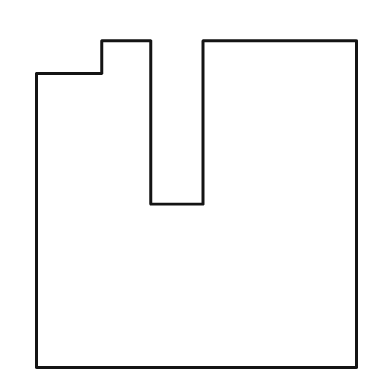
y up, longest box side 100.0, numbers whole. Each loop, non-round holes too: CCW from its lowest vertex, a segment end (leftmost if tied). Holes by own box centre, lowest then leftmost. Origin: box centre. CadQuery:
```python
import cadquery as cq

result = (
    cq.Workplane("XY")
    .moveTo(-49.0, -50.0)
    .lineTo(49.0, -50.0)
    .lineTo(49.0, 50.0)
    .lineTo(2.0, 50.0)
    .lineTo(2.0, 0.0)
    .lineTo(-14.0, 0.0)
    .lineTo(-14.0, 50.0)
    .lineTo(-29.0, 50.0)
    .lineTo(-29.0, 40.0)
    .lineTo(-49.0, 40.0)
    .close()
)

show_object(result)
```